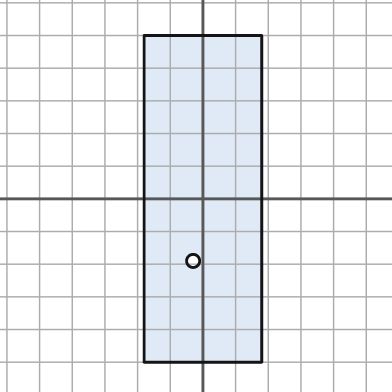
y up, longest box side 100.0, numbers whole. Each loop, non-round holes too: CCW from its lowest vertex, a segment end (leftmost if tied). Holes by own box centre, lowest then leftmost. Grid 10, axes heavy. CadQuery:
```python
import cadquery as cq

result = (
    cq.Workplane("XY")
    .moveTo(-18.0, -50.0)
    .lineTo(18.0, -50.0)
    .lineTo(18.0, 50.0)
    .lineTo(-18.0, 50.0)
    .close()
    .moveTo(-3.0, -19.0)
    .circle(2.0)
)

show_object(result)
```